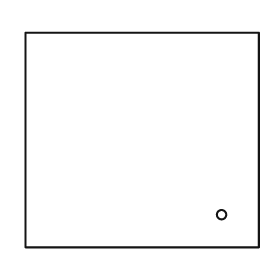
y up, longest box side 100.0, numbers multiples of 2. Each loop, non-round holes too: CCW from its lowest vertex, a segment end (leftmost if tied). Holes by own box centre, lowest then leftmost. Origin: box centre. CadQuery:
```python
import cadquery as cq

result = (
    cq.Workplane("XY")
    .moveTo(-50.0, -46.0)
    .lineTo(50.0, -46.0)
    .lineTo(50.0, 46.0)
    .lineTo(-50.0, 46.0)
    .close()
    .moveTo(34.0, -32.0)
    .circle(2.0)
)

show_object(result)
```